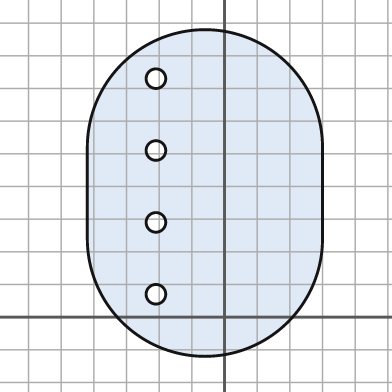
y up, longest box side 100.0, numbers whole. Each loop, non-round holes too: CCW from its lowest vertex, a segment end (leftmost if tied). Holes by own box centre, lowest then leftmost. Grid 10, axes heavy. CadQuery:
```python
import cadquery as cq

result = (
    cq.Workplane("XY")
    .moveTo(-42.0, 24.0)
    .threePointArc((-6.0, -12.0), (30.0, 24.0))
    .lineTo(30.0, 52.0)
    .threePointArc((-6.0, 88.0), (-42.0, 52.0))
    .close()
    .moveTo(-21.0, 7.0)
    .circle(3.0)
    .moveTo(-21.0, 29.0)
    .circle(3.0)
    .moveTo(-21.0, 51.0)
    .circle(3.0)
    .moveTo(-21.0, 73.0)
    .circle(3.0)
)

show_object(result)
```